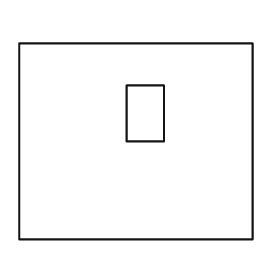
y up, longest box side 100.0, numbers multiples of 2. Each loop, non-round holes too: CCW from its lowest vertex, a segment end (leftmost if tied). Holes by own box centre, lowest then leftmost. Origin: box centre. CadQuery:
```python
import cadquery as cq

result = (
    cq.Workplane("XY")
    .moveTo(-50.0, -42.0)
    .lineTo(50.0, -42.0)
    .lineTo(50.0, 42.0)
    .lineTo(-50.0, 42.0)
    .close()
    .moveTo(-4.0, 0.0)
    .lineTo(12.0, 0.0)
    .lineTo(12.0, 24.0)
    .lineTo(-4.0, 24.0)
    .close()
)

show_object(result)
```